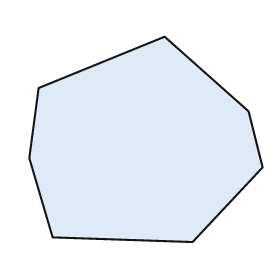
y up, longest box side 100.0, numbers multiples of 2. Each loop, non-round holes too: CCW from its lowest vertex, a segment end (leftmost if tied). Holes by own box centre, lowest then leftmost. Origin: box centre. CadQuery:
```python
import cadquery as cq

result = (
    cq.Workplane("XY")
    .moveTo(20.0, -44.0)
    .lineTo(50.0, -12.0)
    .lineTo(44.0, 12.0)
    .lineTo(8.0, 44.0)
    .lineTo(-46.0, 22.0)
    .lineTo(-50.0, -8.0)
    .lineTo(-40.0, -42.0)
    .close()
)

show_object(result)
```